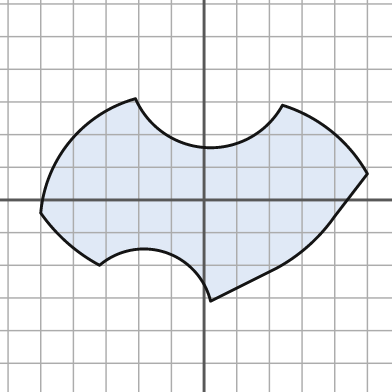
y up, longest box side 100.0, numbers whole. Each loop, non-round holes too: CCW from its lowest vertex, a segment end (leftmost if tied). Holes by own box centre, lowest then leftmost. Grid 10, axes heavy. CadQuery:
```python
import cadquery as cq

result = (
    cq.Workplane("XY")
    .moveTo(2.0, -31.0)
    .lineTo(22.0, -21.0)
    .threePointArc((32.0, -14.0), (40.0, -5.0))
    .lineTo(50.0, 8.0)
    .threePointArc((39.0, 21.0), (24.0, 29.0))
    .threePointArc((1.0, 16.0), (-21.0, 31.0))
    .threePointArc((-41.0, 18.0), (-50.0, -4.0))
    .threePointArc((-42.0, -13.0), (-32.0, -20.0))
    .threePointArc((-12.0, -16.0), (2.0, -31.0))
    .close()
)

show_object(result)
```